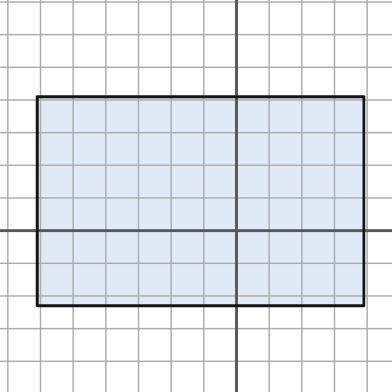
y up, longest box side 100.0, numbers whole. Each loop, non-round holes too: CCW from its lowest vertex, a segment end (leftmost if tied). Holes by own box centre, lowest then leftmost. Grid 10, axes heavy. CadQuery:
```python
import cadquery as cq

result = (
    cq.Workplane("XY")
    .moveTo(-61.0, -23.0)
    .lineTo(39.0, -23.0)
    .lineTo(39.0, 41.0)
    .lineTo(-61.0, 41.0)
    .close()
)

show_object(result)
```